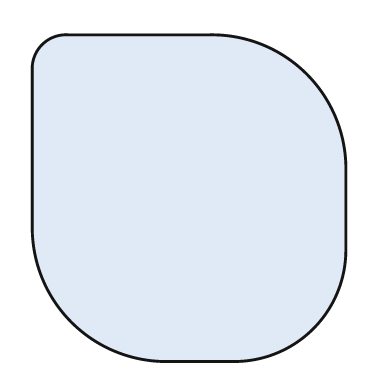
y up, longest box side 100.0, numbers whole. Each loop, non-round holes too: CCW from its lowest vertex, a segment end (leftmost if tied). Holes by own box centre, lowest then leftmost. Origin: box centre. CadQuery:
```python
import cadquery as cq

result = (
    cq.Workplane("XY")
    .moveTo(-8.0, -50.0)
    .lineTo(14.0, -50.0)
    .threePointArc((38.0, -40.0), (48.0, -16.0))
    .lineTo(48.0, 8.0)
    .threePointArc((36.0, 38.0), (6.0, 50.0))
    .lineTo(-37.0, 50.0)
    .threePointArc((-45.0, 47.0), (-48.0, 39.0))
    .lineTo(-48.0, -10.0)
    .threePointArc((-36.0, -38.0), (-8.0, -50.0))
    .close()
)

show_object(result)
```